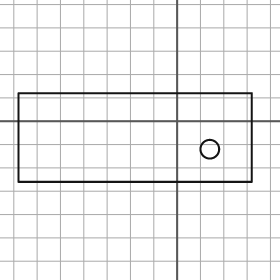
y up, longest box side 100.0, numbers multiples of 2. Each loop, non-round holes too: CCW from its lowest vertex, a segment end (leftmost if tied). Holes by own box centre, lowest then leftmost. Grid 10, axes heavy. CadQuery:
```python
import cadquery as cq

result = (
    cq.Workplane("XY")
    .moveTo(-68.0, -26.0)
    .lineTo(32.0, -26.0)
    .lineTo(32.0, 12.0)
    .lineTo(-68.0, 12.0)
    .close()
    .moveTo(14.0, -12.0)
    .circle(4.0)
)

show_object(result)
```